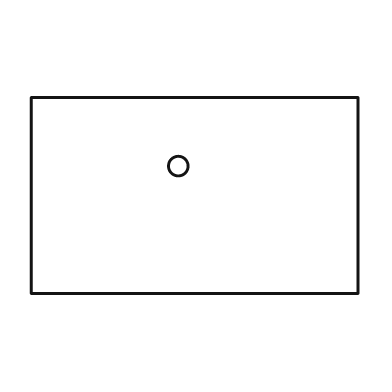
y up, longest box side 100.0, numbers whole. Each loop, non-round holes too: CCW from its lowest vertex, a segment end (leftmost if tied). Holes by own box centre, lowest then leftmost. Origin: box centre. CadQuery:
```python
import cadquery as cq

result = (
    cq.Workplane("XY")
    .moveTo(-50.0, -30.0)
    .lineTo(50.0, -30.0)
    .lineTo(50.0, 30.0)
    .lineTo(-50.0, 30.0)
    .close()
    .moveTo(-5.0, 9.0)
    .circle(3.0)
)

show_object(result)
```